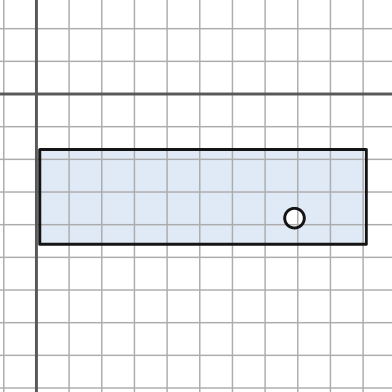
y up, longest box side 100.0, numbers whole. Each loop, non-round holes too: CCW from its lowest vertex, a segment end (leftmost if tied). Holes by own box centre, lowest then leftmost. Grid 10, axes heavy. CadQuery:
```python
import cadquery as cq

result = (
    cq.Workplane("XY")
    .moveTo(1.0, -46.0)
    .lineTo(101.0, -46.0)
    .lineTo(101.0, -17.0)
    .lineTo(1.0, -17.0)
    .close()
    .moveTo(79.0, -38.0)
    .circle(3.0)
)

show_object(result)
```